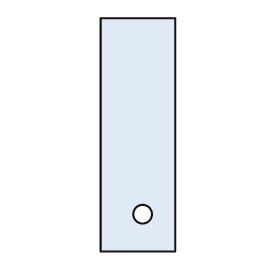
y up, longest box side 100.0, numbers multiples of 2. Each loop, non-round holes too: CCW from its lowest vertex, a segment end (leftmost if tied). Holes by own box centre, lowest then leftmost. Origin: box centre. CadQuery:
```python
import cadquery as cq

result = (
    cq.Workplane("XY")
    .moveTo(-16.0, -50.0)
    .lineTo(16.0, -50.0)
    .lineTo(16.0, 50.0)
    .lineTo(-16.0, 50.0)
    .close()
    .moveTo(2.0, -34.0)
    .circle(4.0)
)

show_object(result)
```